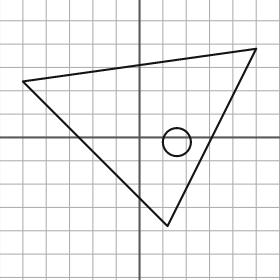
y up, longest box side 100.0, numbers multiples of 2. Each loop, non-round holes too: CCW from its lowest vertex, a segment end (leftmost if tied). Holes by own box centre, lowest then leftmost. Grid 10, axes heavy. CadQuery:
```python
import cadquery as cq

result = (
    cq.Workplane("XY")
    .moveTo(12.0, -38.0)
    .lineTo(50.0, 38.0)
    .lineTo(-50.0, 24.0)
    .close()
    .moveTo(16.0, -2.0)
    .circle(6.0)
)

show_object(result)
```